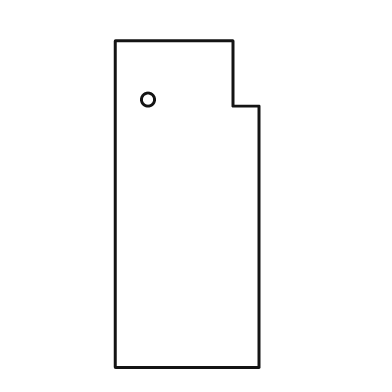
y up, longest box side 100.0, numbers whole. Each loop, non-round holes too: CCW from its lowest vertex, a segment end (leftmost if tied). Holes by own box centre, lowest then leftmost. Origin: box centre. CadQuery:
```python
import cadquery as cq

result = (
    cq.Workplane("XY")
    .moveTo(-22.0, -50.0)
    .lineTo(22.0, -50.0)
    .lineTo(22.0, 30.0)
    .lineTo(14.0, 30.0)
    .lineTo(14.0, 50.0)
    .lineTo(-22.0, 50.0)
    .close()
    .moveTo(-12.0, 32.0)
    .circle(2.0)
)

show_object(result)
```